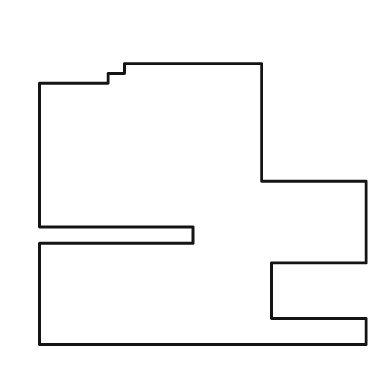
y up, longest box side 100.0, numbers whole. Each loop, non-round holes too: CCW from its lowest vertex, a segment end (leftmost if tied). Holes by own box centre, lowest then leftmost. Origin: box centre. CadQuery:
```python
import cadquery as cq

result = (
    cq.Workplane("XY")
    .moveTo(-50.0, -43.0)
    .lineTo(50.0, -43.0)
    .lineTo(50.0, -35.0)
    .lineTo(21.0, -35.0)
    .lineTo(21.0, -18.0)
    .lineTo(50.0, -18.0)
    .lineTo(50.0, 7.0)
    .lineTo(18.0, 7.0)
    .lineTo(18.0, 43.0)
    .lineTo(-24.0, 43.0)
    .lineTo(-24.0, 40.0)
    .lineTo(-29.0, 40.0)
    .lineTo(-29.0, 37.0)
    .lineTo(-50.0, 37.0)
    .lineTo(-50.0, -7.0)
    .lineTo(-3.0, -7.0)
    .lineTo(-3.0, -12.0)
    .lineTo(-50.0, -12.0)
    .close()
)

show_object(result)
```